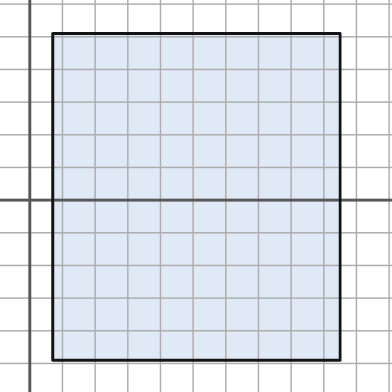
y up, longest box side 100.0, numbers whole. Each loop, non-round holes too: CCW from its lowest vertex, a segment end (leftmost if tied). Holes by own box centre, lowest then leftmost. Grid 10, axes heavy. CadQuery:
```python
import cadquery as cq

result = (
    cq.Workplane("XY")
    .moveTo(7.0, -49.0)
    .lineTo(95.0, -49.0)
    .lineTo(95.0, 51.0)
    .lineTo(7.0, 51.0)
    .close()
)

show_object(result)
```